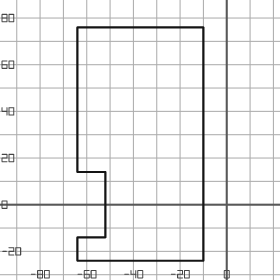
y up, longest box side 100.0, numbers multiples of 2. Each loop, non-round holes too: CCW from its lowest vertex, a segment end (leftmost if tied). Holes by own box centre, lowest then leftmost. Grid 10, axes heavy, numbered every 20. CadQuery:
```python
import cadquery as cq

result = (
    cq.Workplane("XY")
    .moveTo(-64.0, -24.0)
    .lineTo(-10.0, -24.0)
    .lineTo(-10.0, 76.0)
    .lineTo(-64.0, 76.0)
    .lineTo(-64.0, 14.0)
    .lineTo(-52.0, 14.0)
    .lineTo(-52.0, -14.0)
    .lineTo(-64.0, -14.0)
    .close()
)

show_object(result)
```